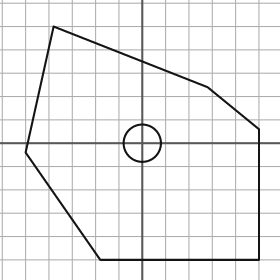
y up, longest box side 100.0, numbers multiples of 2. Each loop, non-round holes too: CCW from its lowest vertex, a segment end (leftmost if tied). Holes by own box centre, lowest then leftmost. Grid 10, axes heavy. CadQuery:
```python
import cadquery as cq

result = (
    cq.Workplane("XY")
    .moveTo(-18.0, -50.0)
    .lineTo(50.0, -50.0)
    .lineTo(50.0, 6.0)
    .lineTo(28.0, 24.0)
    .lineTo(-38.0, 50.0)
    .lineTo(-50.0, -4.0)
    .close()
    .moveTo(0.0, 0.0)
    .circle(8.0)
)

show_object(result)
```